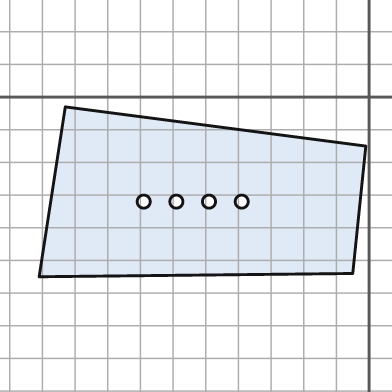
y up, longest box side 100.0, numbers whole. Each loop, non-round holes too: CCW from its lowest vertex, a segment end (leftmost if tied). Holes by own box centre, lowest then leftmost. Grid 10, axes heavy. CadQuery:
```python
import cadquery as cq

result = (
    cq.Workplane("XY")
    .moveTo(-101.0, -55.0)
    .lineTo(-5.0, -54.0)
    .lineTo(-1.0, -15.0)
    .lineTo(-93.0, -3.0)
    .close()
    .moveTo(-69.0, -32.0)
    .circle(2.0)
    .moveTo(-59.0, -32.0)
    .circle(2.0)
    .moveTo(-49.0, -32.0)
    .circle(2.0)
    .moveTo(-39.0, -32.0)
    .circle(2.0)
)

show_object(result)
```